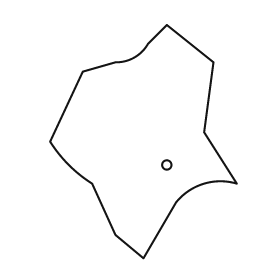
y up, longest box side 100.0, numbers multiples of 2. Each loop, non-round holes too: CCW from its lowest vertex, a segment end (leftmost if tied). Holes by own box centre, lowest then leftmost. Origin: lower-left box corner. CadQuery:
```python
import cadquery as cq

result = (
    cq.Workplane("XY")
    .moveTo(40.0, 0.0)
    .lineTo(54.0, 24.0)
    .threePointArc((66.0, 32.0), (80.0, 32.0))
    .lineTo(66.0, 54.0)
    .lineTo(70.0, 84.0)
    .lineTo(50.0, 100.0)
    .lineTo(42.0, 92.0)
    .threePointArc((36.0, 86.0), (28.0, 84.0))
    .lineTo(14.0, 80.0)
    .lineTo(0.0, 50.0)
    .threePointArc((8.0, 40.0), (18.0, 32.0))
    .lineTo(28.0, 10.0)
    .close()
    .moveTo(50.0, 40.0)
    .circle(2.0)
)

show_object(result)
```